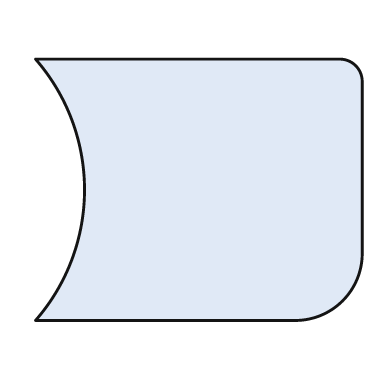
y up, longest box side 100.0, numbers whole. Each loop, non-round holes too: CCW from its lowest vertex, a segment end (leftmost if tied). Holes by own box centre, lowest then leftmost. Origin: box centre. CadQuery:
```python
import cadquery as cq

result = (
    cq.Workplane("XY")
    .moveTo(-50.0, -40.0)
    .lineTo(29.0, -40.0)
    .threePointArc((44.0, -34.0), (50.0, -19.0))
    .lineTo(50.0, 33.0)
    .threePointArc((48.0, 38.0), (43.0, 40.0))
    .lineTo(-50.0, 40.0)
    .threePointArc((-35.0, 0.0), (-50.0, -40.0))
    .close()
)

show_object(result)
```